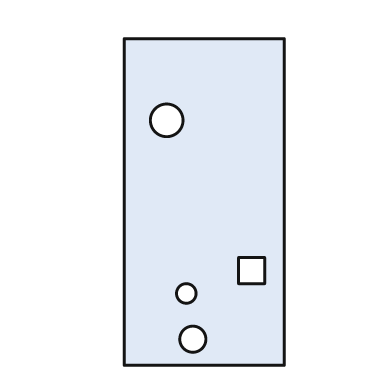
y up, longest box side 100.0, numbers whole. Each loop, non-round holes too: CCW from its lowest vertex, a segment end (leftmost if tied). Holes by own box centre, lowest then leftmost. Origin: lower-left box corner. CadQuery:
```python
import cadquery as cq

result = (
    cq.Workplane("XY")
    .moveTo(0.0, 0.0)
    .lineTo(49.0, 0.0)
    .lineTo(49.0, 100.0)
    .lineTo(0.0, 100.0)
    .close()
    .moveTo(21.0, 8.0)
    .circle(4.0)
    .moveTo(19.0, 22.0)
    .circle(3.0)
    .moveTo(35.0, 25.0)
    .lineTo(43.0, 25.0)
    .lineTo(43.0, 33.0)
    .lineTo(35.0, 33.0)
    .close()
    .moveTo(13.0, 75.0)
    .circle(5.0)
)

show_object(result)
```